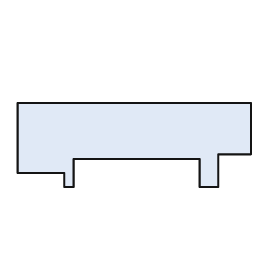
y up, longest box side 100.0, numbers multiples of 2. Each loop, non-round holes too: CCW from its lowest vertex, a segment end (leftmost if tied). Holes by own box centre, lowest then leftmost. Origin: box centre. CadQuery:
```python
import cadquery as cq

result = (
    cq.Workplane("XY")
    .moveTo(-30.0, -18.0)
    .lineTo(-26.0, -18.0)
    .lineTo(-26.0, -6.0)
    .lineTo(28.0, -6.0)
    .lineTo(28.0, -18.0)
    .lineTo(36.0, -18.0)
    .lineTo(36.0, -4.0)
    .lineTo(50.0, -4.0)
    .lineTo(50.0, 18.0)
    .lineTo(-50.0, 18.0)
    .lineTo(-50.0, -12.0)
    .lineTo(-30.0, -12.0)
    .close()
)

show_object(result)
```